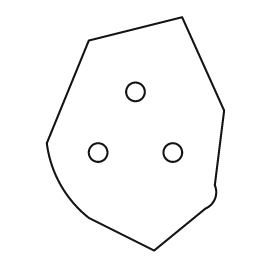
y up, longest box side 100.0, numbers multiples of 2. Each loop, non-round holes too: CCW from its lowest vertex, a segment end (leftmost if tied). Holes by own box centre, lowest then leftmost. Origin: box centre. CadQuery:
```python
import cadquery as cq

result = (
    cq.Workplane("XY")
    .moveTo(8.0, -50.0)
    .lineTo(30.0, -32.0)
    .threePointArc((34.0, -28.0), (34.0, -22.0))
    .lineTo(38.0, 10.0)
    .lineTo(20.0, 50.0)
    .lineTo(-20.0, 40.0)
    .lineTo(-38.0, -4.0)
    .threePointArc((-32.0, -22.0), (-20.0, -36.0))
    .close()
    .moveTo(-16.0, -8.0)
    .circle(4.0)
    .moveTo(16.0, -8.0)
    .circle(4.0)
    .moveTo(0.0, 18.0)
    .circle(4.0)
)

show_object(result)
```